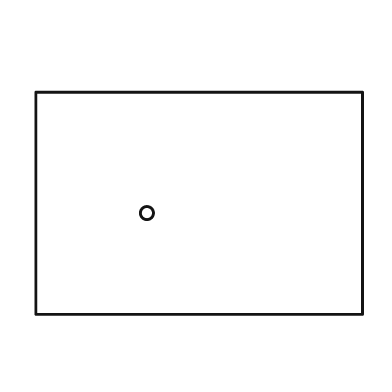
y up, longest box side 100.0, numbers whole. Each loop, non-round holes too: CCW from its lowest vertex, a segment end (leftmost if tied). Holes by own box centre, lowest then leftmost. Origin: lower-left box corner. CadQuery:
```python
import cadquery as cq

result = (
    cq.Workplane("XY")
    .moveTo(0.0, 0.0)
    .lineTo(100.0, 0.0)
    .lineTo(100.0, 68.0)
    .lineTo(0.0, 68.0)
    .close()
    .moveTo(34.0, 31.0)
    .circle(2.0)
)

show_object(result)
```